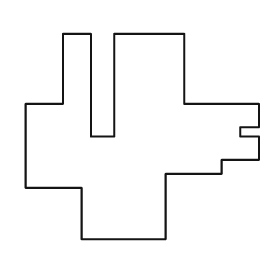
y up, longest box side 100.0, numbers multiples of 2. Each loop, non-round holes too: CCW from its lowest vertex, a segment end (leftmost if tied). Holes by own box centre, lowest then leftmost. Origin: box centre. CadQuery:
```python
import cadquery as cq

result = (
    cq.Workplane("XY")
    .moveTo(-26.0, -44.0)
    .lineTo(10.0, -44.0)
    .lineTo(10.0, -16.0)
    .lineTo(34.0, -16.0)
    .lineTo(34.0, -10.0)
    .lineTo(50.0, -10.0)
    .lineTo(50.0, 0.0)
    .lineTo(42.0, 0.0)
    .lineTo(42.0, 4.0)
    .lineTo(50.0, 4.0)
    .lineTo(50.0, 14.0)
    .lineTo(18.0, 14.0)
    .lineTo(18.0, 44.0)
    .lineTo(-12.0, 44.0)
    .lineTo(-12.0, 0.0)
    .lineTo(-22.0, 0.0)
    .lineTo(-22.0, 44.0)
    .lineTo(-34.0, 44.0)
    .lineTo(-34.0, 14.0)
    .lineTo(-50.0, 14.0)
    .lineTo(-50.0, -22.0)
    .lineTo(-26.0, -22.0)
    .close()
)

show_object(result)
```